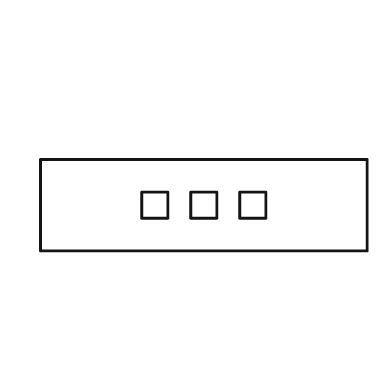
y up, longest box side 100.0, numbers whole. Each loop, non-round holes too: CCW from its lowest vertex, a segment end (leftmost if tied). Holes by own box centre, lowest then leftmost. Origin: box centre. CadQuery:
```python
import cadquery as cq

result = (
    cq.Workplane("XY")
    .moveTo(-50.0, -14.0)
    .lineTo(50.0, -14.0)
    .lineTo(50.0, 14.0)
    .lineTo(-50.0, 14.0)
    .close()
    .moveTo(-19.0, -4.0)
    .lineTo(-11.0, -4.0)
    .lineTo(-11.0, 4.0)
    .lineTo(-19.0, 4.0)
    .close()
    .moveTo(-4.0, -4.0)
    .lineTo(4.0, -4.0)
    .lineTo(4.0, 4.0)
    .lineTo(-4.0, 4.0)
    .close()
    .moveTo(11.0, -4.0)
    .lineTo(19.0, -4.0)
    .lineTo(19.0, 4.0)
    .lineTo(11.0, 4.0)
    .close()
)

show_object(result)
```